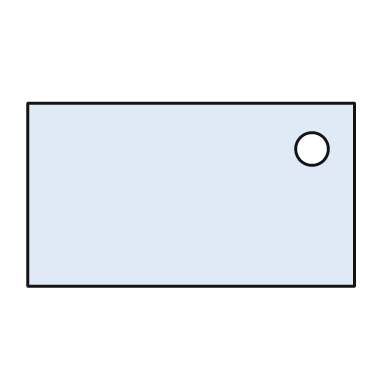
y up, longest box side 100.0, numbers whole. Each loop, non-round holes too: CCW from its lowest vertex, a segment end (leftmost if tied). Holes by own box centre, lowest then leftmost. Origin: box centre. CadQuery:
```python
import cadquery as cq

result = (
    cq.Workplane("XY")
    .moveTo(-50.0, -28.0)
    .lineTo(50.0, -28.0)
    .lineTo(50.0, 28.0)
    .lineTo(-50.0, 28.0)
    .close()
    .moveTo(37.0, 14.0)
    .circle(5.0)
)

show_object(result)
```